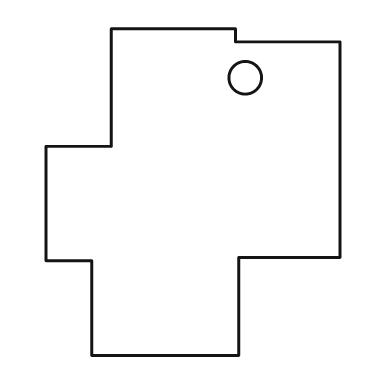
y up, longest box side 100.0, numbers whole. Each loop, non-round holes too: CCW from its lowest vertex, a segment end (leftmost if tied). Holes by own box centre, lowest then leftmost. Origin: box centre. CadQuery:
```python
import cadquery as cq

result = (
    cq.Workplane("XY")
    .moveTo(-31.0, -50.0)
    .lineTo(14.0, -50.0)
    .lineTo(14.0, -20.0)
    .lineTo(45.0, -20.0)
    .lineTo(45.0, 46.0)
    .lineTo(13.0, 46.0)
    .lineTo(13.0, 50.0)
    .lineTo(-25.0, 50.0)
    .lineTo(-25.0, 14.0)
    .lineTo(-45.0, 14.0)
    .lineTo(-45.0, -21.0)
    .lineTo(-31.0, -21.0)
    .close()
    .moveTo(16.0, 35.0)
    .circle(5.0)
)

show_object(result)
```